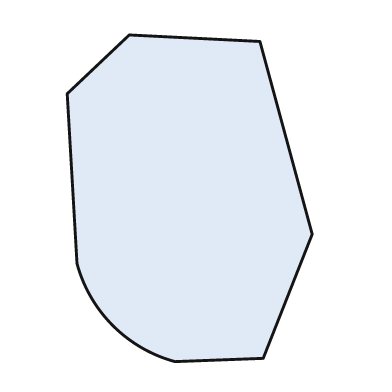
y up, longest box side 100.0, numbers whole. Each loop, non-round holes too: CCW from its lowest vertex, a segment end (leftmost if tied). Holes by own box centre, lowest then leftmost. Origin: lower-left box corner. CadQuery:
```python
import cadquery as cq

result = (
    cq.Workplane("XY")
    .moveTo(33.0, 0.0)
    .lineTo(60.0, 1.0)
    .lineTo(75.0, 39.0)
    .lineTo(59.0, 98.0)
    .lineTo(19.0, 100.0)
    .lineTo(0.0, 82.0)
    .lineTo(3.0, 30.0)
    .threePointArc((14.0, 11.0), (33.0, 0.0))
    .close()
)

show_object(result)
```